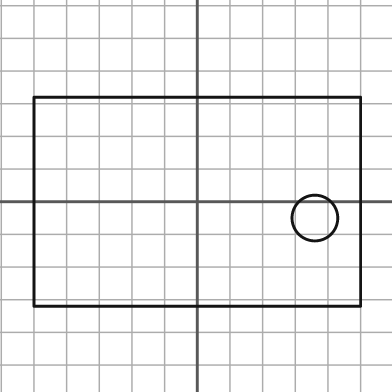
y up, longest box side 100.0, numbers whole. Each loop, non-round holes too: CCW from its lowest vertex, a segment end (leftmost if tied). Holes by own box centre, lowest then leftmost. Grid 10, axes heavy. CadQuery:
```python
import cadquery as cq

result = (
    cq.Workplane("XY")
    .moveTo(-50.0, -32.0)
    .lineTo(50.0, -32.0)
    .lineTo(50.0, 32.0)
    .lineTo(-50.0, 32.0)
    .close()
    .moveTo(36.0, -5.0)
    .circle(7.0)
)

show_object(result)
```